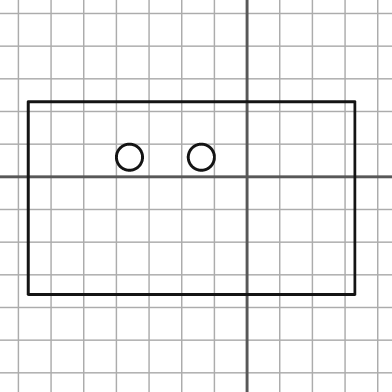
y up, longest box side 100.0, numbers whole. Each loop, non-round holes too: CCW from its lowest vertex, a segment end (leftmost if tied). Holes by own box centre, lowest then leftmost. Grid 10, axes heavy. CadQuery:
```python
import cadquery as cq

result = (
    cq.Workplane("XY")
    .moveTo(-67.0, -36.0)
    .lineTo(33.0, -36.0)
    .lineTo(33.0, 23.0)
    .lineTo(-67.0, 23.0)
    .close()
    .moveTo(-36.0, 6.0)
    .circle(4.0)
    .moveTo(-14.0, 6.0)
    .circle(4.0)
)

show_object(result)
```